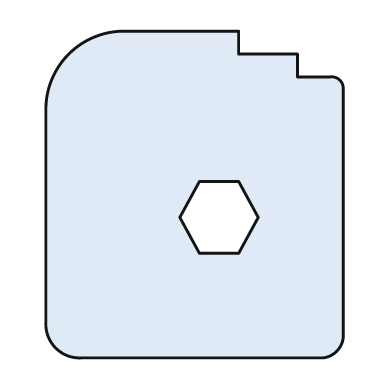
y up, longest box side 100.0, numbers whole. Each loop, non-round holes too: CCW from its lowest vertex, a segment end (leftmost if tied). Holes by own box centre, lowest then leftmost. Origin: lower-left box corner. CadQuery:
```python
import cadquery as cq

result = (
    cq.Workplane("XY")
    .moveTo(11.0, 0.0)
    .lineTo(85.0, 0.0)
    .threePointArc((89.0, 2.0), (91.0, 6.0))
    .lineTo(91.0, 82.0)
    .threePointArc((90.0, 85.0), (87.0, 86.0))
    .lineTo(77.0, 86.0)
    .lineTo(77.0, 93.0)
    .lineTo(59.0, 93.0)
    .lineTo(59.0, 100.0)
    .lineTo(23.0, 100.0)
    .threePointArc((7.0, 93.0), (0.0, 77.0))
    .lineTo(0.0, 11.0)
    .threePointArc((3.0, 3.0), (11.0, 0.0))
    .close()
    .moveTo(47.0, 32.0)
    .lineTo(59.0, 32.0)
    .lineTo(65.0, 43.0)
    .lineTo(59.0, 54.0)
    .lineTo(47.0, 54.0)
    .lineTo(41.0, 43.0)
    .close()
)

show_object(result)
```